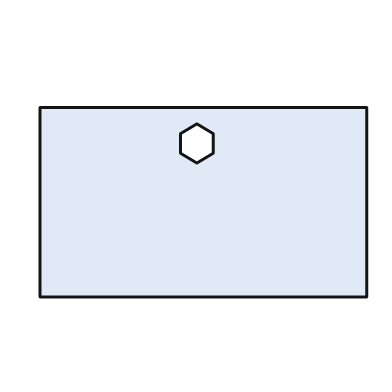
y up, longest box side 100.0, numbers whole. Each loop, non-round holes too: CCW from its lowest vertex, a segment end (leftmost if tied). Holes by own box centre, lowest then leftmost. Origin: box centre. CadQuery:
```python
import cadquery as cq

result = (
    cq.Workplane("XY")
    .moveTo(-50.0, -29.0)
    .lineTo(50.0, -29.0)
    .lineTo(50.0, 29.0)
    .lineTo(-50.0, 29.0)
    .close()
    .moveTo(-2.0, 12.0)
    .lineTo(3.0, 15.0)
    .lineTo(3.0, 21.0)
    .lineTo(-2.0, 24.0)
    .lineTo(-7.0, 21.0)
    .lineTo(-7.0, 15.0)
    .close()
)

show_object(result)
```